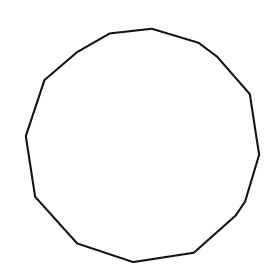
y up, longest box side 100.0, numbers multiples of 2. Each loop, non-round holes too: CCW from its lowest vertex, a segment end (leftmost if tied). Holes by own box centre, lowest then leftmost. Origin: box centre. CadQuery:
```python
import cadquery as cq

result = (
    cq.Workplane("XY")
    .moveTo(-4.0, -50.0)
    .lineTo(22.0, -46.0)
    .lineTo(40.0, -30.0)
    .lineTo(44.0, -24.0)
    .lineTo(50.0, -4.0)
    .lineTo(46.0, 22.0)
    .lineTo(32.0, 38.0)
    .lineTo(24.0, 44.0)
    .lineTo(4.0, 50.0)
    .lineTo(-14.0, 48.0)
    .lineTo(-28.0, 40.0)
    .lineTo(-42.0, 28.0)
    .lineTo(-50.0, 4.0)
    .lineTo(-46.0, -22.0)
    .lineTo(-28.0, -42.0)
    .close()
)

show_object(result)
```